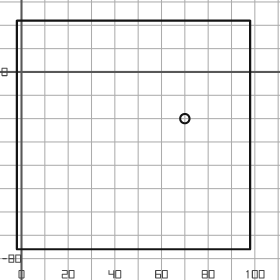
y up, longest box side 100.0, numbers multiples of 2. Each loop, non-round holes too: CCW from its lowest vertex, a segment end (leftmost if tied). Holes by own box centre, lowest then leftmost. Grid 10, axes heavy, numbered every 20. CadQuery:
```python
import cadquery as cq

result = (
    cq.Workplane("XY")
    .moveTo(-2.0, -76.0)
    .lineTo(98.0, -76.0)
    .lineTo(98.0, 22.0)
    .lineTo(-2.0, 22.0)
    .close()
    .moveTo(70.0, -20.0)
    .circle(2.0)
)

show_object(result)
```